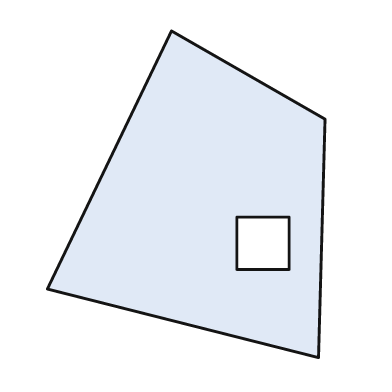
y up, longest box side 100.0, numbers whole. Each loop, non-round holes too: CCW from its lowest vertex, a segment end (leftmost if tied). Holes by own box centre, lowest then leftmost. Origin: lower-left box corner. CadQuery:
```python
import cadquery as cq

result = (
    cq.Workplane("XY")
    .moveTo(83.0, 0.0)
    .lineTo(85.0, 73.0)
    .lineTo(38.0, 100.0)
    .lineTo(0.0, 21.0)
    .close()
    .moveTo(58.0, 27.0)
    .lineTo(74.0, 27.0)
    .lineTo(74.0, 43.0)
    .lineTo(58.0, 43.0)
    .close()
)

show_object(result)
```